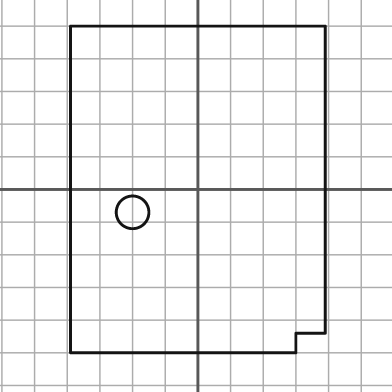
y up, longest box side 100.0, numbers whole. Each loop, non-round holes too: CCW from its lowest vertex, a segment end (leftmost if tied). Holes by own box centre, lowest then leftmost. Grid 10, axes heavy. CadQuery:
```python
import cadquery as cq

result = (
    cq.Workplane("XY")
    .moveTo(-39.0, -50.0)
    .lineTo(30.0, -50.0)
    .lineTo(30.0, -44.0)
    .lineTo(39.0, -44.0)
    .lineTo(39.0, 50.0)
    .lineTo(-39.0, 50.0)
    .close()
    .moveTo(-20.0, -7.0)
    .circle(5.0)
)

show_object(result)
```